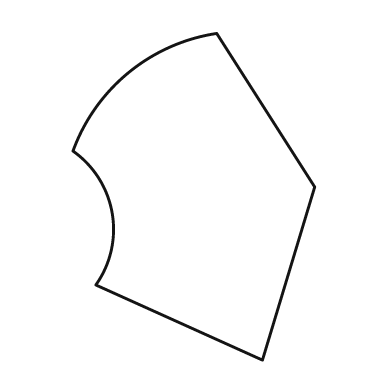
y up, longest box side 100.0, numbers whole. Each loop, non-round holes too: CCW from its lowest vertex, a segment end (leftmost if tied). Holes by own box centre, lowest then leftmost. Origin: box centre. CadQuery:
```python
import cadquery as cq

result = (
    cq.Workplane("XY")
    .moveTo(21.0, -50.0)
    .lineTo(37.0, 3.0)
    .lineTo(7.0, 50.0)
    .threePointArc((-20.0, 38.0), (-37.0, 14.0))
    .threePointArc((-25.0, -5.0), (-30.0, -27.0))
    .close()
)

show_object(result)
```